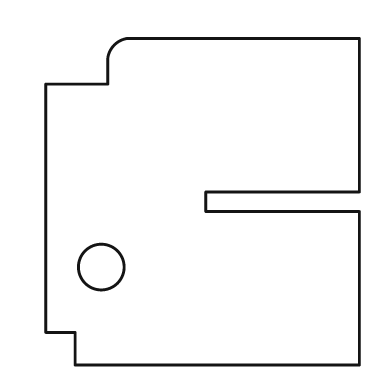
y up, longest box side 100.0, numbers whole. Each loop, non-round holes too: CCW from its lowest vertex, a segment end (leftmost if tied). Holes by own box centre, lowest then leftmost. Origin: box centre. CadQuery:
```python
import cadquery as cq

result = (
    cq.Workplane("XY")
    .moveTo(-39.0, -50.0)
    .lineTo(48.0, -50.0)
    .lineTo(48.0, -3.0)
    .lineTo(1.0, -3.0)
    .lineTo(1.0, 3.0)
    .lineTo(48.0, 3.0)
    .lineTo(48.0, 50.0)
    .lineTo(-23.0, 50.0)
    .threePointArc((-27.0, 48.0), (-29.0, 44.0))
    .lineTo(-29.0, 36.0)
    .lineTo(-48.0, 36.0)
    .lineTo(-48.0, -40.0)
    .lineTo(-39.0, -40.0)
    .close()
    .moveTo(-31.0, -20.0)
    .circle(7.0)
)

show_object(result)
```